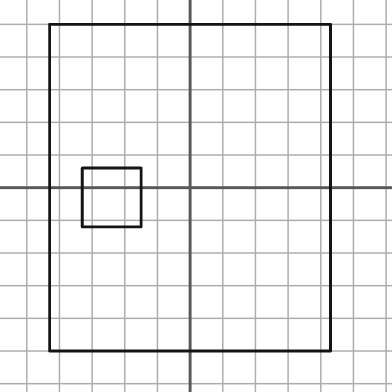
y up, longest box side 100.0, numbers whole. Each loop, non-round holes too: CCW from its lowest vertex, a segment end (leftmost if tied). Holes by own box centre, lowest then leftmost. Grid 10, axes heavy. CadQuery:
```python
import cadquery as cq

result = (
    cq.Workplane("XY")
    .moveTo(-43.0, -50.0)
    .lineTo(43.0, -50.0)
    .lineTo(43.0, 50.0)
    .lineTo(-43.0, 50.0)
    .close()
    .moveTo(-33.0, -12.0)
    .lineTo(-15.0, -12.0)
    .lineTo(-15.0, 6.0)
    .lineTo(-33.0, 6.0)
    .close()
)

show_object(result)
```